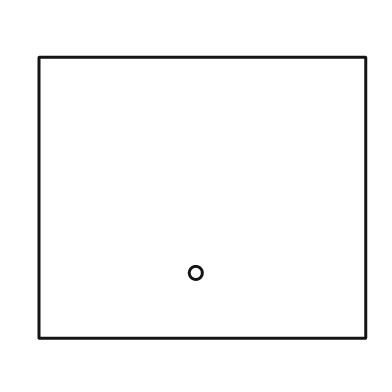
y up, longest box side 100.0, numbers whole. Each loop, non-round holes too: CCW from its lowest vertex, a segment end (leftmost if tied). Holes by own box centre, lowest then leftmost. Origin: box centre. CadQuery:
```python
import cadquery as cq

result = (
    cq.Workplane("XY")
    .moveTo(-50.0, -43.0)
    .lineTo(50.0, -43.0)
    .lineTo(50.0, 43.0)
    .lineTo(-50.0, 43.0)
    .close()
    .moveTo(-2.0, -23.0)
    .circle(2.0)
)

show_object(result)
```